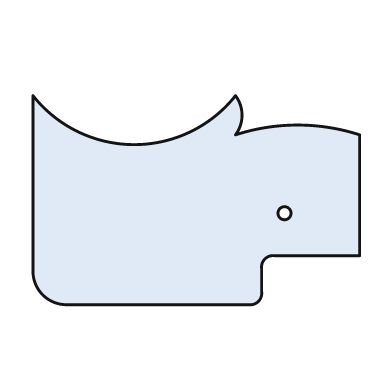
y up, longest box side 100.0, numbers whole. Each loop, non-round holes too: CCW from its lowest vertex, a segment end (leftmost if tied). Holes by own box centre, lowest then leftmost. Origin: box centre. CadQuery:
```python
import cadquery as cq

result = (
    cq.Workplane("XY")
    .moveTo(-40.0, -32.0)
    .lineTo(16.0, -32.0)
    .threePointArc((19.0, -31.0), (20.0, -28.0))
    .lineTo(20.0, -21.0)
    .threePointArc((21.0, -18.0), (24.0, -17.0))
    .lineTo(50.0, -17.0)
    .lineTo(50.0, 20.0)
    .threePointArc((31.0, 23.0), (12.0, 20.0))
    .threePointArc((14.0, 26.0), (12.0, 32.0))
    .threePointArc((-19.0, 17.0), (-50.0, 32.0))
    .lineTo(-50.0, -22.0)
    .threePointArc((-47.0, -29.0), (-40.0, -32.0))
    .close()
    .moveTo(27.0, -4.0)
    .circle(2.0)
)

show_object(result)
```